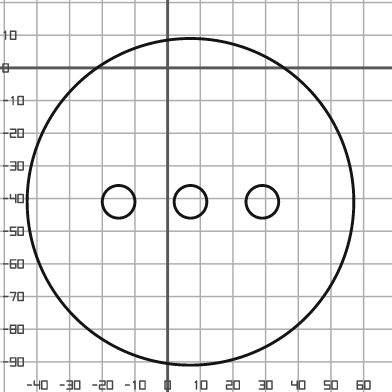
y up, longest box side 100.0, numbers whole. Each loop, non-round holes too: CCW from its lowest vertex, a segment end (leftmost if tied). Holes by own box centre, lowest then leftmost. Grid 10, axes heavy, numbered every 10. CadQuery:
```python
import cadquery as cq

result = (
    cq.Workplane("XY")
    .moveTo(7.0, -41.0)
    .circle(50.0)
    .moveTo(-15.0, -41.0)
    .circle(5.0)
    .moveTo(7.0, -41.0)
    .circle(5.0)
    .moveTo(29.0, -41.0)
    .circle(5.0)
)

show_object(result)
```